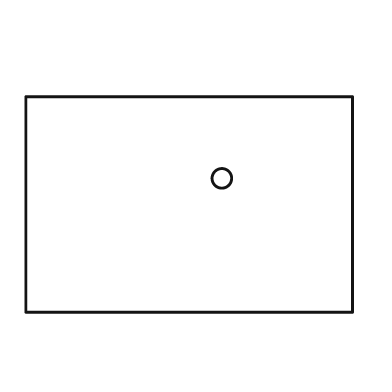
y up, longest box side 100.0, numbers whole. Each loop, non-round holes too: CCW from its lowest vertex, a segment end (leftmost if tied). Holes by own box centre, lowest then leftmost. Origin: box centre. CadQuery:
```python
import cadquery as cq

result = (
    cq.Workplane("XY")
    .moveTo(-50.0, -33.0)
    .lineTo(50.0, -33.0)
    .lineTo(50.0, 33.0)
    .lineTo(-50.0, 33.0)
    .close()
    .moveTo(10.0, 8.0)
    .circle(3.0)
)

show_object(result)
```